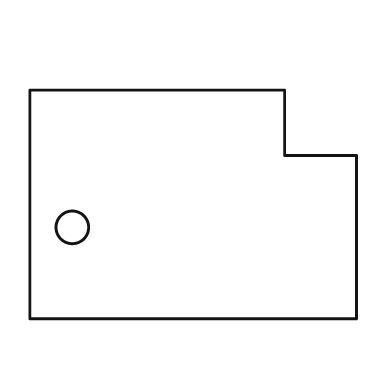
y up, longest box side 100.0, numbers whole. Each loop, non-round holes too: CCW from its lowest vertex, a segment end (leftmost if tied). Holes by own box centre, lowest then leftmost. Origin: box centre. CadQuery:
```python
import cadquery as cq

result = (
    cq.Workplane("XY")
    .moveTo(-50.0, -35.0)
    .lineTo(50.0, -35.0)
    .lineTo(50.0, 15.0)
    .lineTo(28.0, 15.0)
    .lineTo(28.0, 35.0)
    .lineTo(-50.0, 35.0)
    .close()
    .moveTo(-37.0, -7.0)
    .circle(5.0)
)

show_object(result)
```